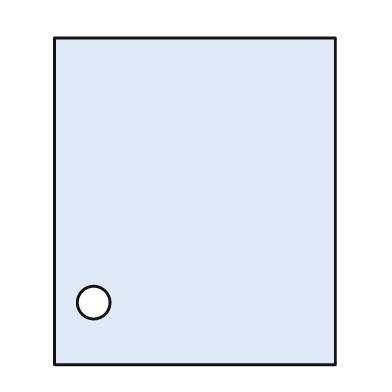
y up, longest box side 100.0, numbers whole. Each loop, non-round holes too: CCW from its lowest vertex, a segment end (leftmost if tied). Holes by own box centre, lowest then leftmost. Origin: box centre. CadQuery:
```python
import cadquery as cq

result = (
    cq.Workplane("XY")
    .moveTo(-43.0, -50.0)
    .lineTo(43.0, -50.0)
    .lineTo(43.0, 50.0)
    .lineTo(-43.0, 50.0)
    .close()
    .moveTo(-31.0, -31.0)
    .circle(5.0)
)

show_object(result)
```